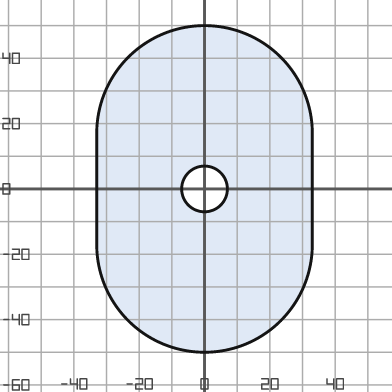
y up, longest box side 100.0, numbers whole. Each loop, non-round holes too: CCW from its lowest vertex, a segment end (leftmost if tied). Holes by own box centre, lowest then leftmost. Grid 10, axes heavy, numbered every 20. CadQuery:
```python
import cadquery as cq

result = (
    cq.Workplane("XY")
    .moveTo(-33.0, -17.0)
    .threePointArc((0.0, -50.0), (33.0, -17.0))
    .lineTo(33.0, 17.0)
    .threePointArc((0.0, 50.0), (-33.0, 17.0))
    .close()
    .moveTo(0.0, 0.0)
    .circle(7.0)
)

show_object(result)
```